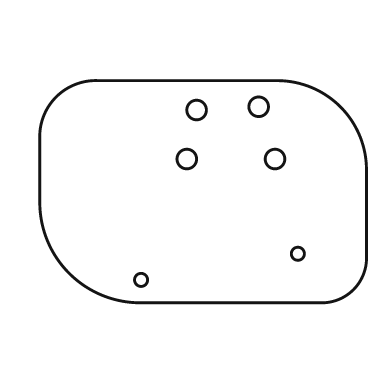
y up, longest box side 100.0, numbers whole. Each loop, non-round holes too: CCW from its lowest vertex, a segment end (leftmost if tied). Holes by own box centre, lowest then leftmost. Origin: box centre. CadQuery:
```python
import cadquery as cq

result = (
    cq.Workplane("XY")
    .moveTo(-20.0, -34.0)
    .lineTo(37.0, -34.0)
    .threePointArc((46.0, -30.0), (50.0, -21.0))
    .lineTo(50.0, 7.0)
    .threePointArc((42.0, 26.0), (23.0, 34.0))
    .lineTo(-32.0, 34.0)
    .threePointArc((-45.0, 29.0), (-50.0, 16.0))
    .lineTo(-50.0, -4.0)
    .threePointArc((-41.0, -25.0), (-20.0, -34.0))
    .close()
    .moveTo(-19.0, -27.0)
    .circle(2.0)
    .moveTo(29.0, -19.0)
    .circle(2.0)
    .moveTo(-5.0, 10.0)
    .circle(3.0)
    .moveTo(22.0, 10.0)
    .circle(3.0)
    .moveTo(-2.0, 25.0)
    .circle(3.0)
    .moveTo(17.0, 26.0)
    .circle(3.0)
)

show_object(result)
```